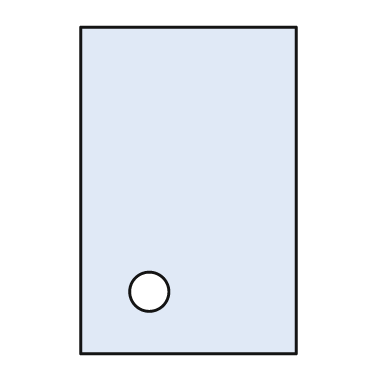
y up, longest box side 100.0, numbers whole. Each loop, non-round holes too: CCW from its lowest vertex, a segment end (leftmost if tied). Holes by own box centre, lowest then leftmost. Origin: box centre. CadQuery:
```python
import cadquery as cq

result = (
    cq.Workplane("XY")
    .moveTo(-33.0, -50.0)
    .lineTo(33.0, -50.0)
    .lineTo(33.0, 50.0)
    .lineTo(-33.0, 50.0)
    .close()
    .moveTo(-12.0, -31.0)
    .circle(6.0)
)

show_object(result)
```